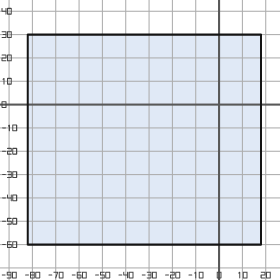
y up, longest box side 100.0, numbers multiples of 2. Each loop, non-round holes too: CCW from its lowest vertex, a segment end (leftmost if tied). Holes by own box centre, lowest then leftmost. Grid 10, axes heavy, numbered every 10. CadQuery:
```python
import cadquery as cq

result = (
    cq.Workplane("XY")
    .moveTo(-82.0, -60.0)
    .lineTo(18.0, -60.0)
    .lineTo(18.0, 30.0)
    .lineTo(-82.0, 30.0)
    .close()
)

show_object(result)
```